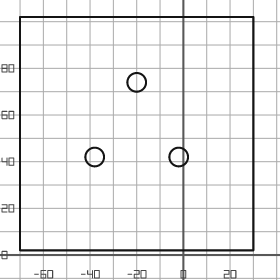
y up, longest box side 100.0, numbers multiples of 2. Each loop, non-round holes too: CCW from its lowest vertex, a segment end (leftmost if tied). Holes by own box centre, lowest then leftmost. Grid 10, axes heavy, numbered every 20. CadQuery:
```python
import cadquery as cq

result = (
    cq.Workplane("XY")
    .moveTo(-70.0, 2.0)
    .lineTo(30.0, 2.0)
    .lineTo(30.0, 102.0)
    .lineTo(-70.0, 102.0)
    .close()
    .moveTo(-38.0, 42.0)
    .circle(4.0)
    .moveTo(-2.0, 42.0)
    .circle(4.0)
    .moveTo(-20.0, 74.0)
    .circle(4.0)
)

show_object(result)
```